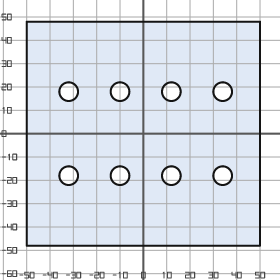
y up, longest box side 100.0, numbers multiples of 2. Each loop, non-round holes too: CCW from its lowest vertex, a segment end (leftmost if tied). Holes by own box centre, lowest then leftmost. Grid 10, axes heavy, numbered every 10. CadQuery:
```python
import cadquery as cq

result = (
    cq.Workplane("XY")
    .moveTo(-50.0, -48.0)
    .lineTo(50.0, -48.0)
    .lineTo(50.0, 48.0)
    .lineTo(-50.0, 48.0)
    .close()
    .moveTo(-32.0, -18.0)
    .circle(4.0)
    .moveTo(-10.0, -18.0)
    .circle(4.0)
    .moveTo(12.0, -18.0)
    .circle(4.0)
    .moveTo(34.0, -18.0)
    .circle(4.0)
    .moveTo(-32.0, 18.0)
    .circle(4.0)
    .moveTo(-10.0, 18.0)
    .circle(4.0)
    .moveTo(12.0, 18.0)
    .circle(4.0)
    .moveTo(34.0, 18.0)
    .circle(4.0)
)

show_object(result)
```